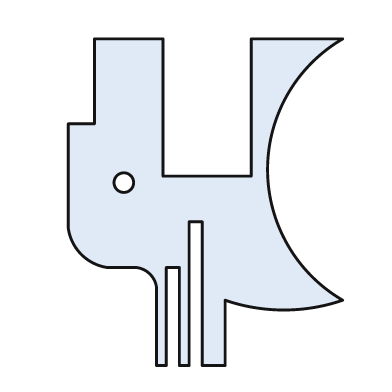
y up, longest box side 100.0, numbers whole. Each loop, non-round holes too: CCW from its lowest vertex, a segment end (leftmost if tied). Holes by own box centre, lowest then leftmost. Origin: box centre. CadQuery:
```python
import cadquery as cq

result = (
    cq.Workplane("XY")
    .moveTo(-15.0, -50.0)
    .lineTo(-12.0, -50.0)
    .lineTo(-12.0, -20.0)
    .lineTo(-8.0, -20.0)
    .lineTo(-8.0, -50.0)
    .lineTo(-5.0, -50.0)
    .lineTo(-5.0, -6.0)
    .lineTo(-1.0, -6.0)
    .lineTo(-1.0, -50.0)
    .lineTo(6.0, -50.0)
    .lineTo(6.0, -30.0)
    .threePointArc((24.0, -33.0), (42.0, -30.0))
    .threePointArc((19.0, 10.0), (42.0, 50.0))
    .lineTo(14.0, 50.0)
    .lineTo(14.0, 8.0)
    .lineTo(-13.0, 8.0)
    .lineTo(-13.0, 50.0)
    .lineTo(-34.0, 50.0)
    .lineTo(-34.0, 24.0)
    .lineTo(-42.0, 24.0)
    .lineTo(-42.0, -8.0)
    .threePointArc((-38.0, -16.0), (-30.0, -20.0))
    .lineTo(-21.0, -20.0)
    .threePointArc((-17.0, -22.0), (-15.0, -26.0))
    .close()
    .moveTo(-25.0, 6.0)
    .circle(3.0)
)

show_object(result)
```